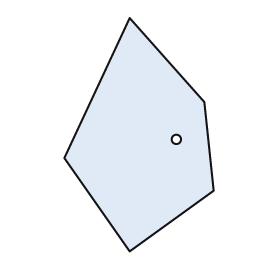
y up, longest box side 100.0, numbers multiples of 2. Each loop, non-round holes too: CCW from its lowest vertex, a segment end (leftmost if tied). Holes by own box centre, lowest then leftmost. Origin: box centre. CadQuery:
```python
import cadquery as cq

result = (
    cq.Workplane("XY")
    .moveTo(-4.0, -50.0)
    .lineTo(32.0, -24.0)
    .lineTo(28.0, 14.0)
    .lineTo(-4.0, 50.0)
    .lineTo(-32.0, -10.0)
    .close()
    .moveTo(16.0, -2.0)
    .circle(2.0)
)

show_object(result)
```